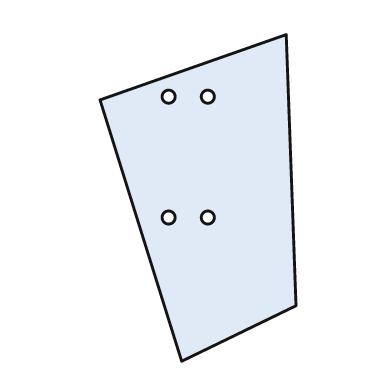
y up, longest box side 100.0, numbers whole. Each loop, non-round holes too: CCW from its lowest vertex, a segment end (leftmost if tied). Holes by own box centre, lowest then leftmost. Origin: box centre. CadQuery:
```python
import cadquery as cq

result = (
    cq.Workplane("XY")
    .moveTo(-5.0, -50.0)
    .lineTo(30.0, -33.0)
    .lineTo(27.0, 50.0)
    .lineTo(-30.0, 30.0)
    .close()
    .moveTo(-9.0, -6.0)
    .circle(2.0)
    .moveTo(3.0, -6.0)
    .circle(2.0)
    .moveTo(-9.0, 31.0)
    .circle(2.0)
    .moveTo(3.0, 31.0)
    .circle(2.0)
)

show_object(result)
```